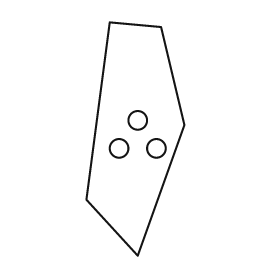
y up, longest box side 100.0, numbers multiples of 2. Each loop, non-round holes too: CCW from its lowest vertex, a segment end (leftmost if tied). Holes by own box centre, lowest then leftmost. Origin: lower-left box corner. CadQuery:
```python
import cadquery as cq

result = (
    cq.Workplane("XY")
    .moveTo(22.0, 0.0)
    .lineTo(42.0, 56.0)
    .lineTo(32.0, 98.0)
    .lineTo(10.0, 100.0)
    .lineTo(0.0, 24.0)
    .close()
    .moveTo(14.0, 46.0)
    .circle(4.0)
    .moveTo(30.0, 46.0)
    .circle(4.0)
    .moveTo(22.0, 58.0)
    .circle(4.0)
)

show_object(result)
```